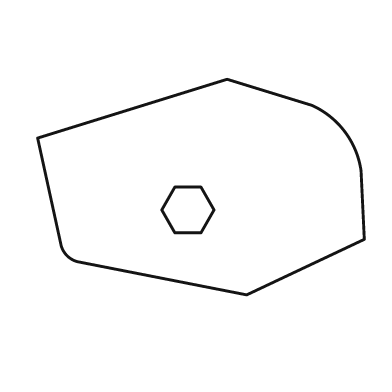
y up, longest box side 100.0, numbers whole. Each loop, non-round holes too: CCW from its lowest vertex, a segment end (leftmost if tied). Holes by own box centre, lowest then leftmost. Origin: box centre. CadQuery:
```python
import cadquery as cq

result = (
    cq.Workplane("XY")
    .moveTo(14.0, -33.0)
    .lineTo(50.0, -16.0)
    .lineTo(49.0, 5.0)
    .threePointArc((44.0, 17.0), (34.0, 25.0))
    .lineTo(8.0, 33.0)
    .lineTo(-50.0, 15.0)
    .lineTo(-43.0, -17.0)
    .threePointArc((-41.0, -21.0), (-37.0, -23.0))
    .close()
    .moveTo(-8.0, -14.0)
    .lineTo(0.0, -14.0)
    .lineTo(4.0, -7.0)
    .lineTo(0.0, 0.0)
    .lineTo(-8.0, 0.0)
    .lineTo(-12.0, -7.0)
    .close()
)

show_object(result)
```